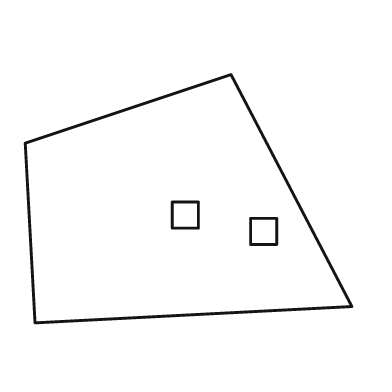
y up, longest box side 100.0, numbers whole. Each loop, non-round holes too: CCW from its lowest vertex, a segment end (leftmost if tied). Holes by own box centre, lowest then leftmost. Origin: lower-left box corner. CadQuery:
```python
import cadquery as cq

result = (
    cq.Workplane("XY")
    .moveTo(3.0, 0.0)
    .lineTo(100.0, 5.0)
    .lineTo(63.0, 76.0)
    .lineTo(0.0, 55.0)
    .close()
    .moveTo(69.0, 24.0)
    .lineTo(77.0, 24.0)
    .lineTo(77.0, 32.0)
    .lineTo(69.0, 32.0)
    .close()
    .moveTo(45.0, 29.0)
    .lineTo(53.0, 29.0)
    .lineTo(53.0, 37.0)
    .lineTo(45.0, 37.0)
    .close()
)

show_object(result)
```